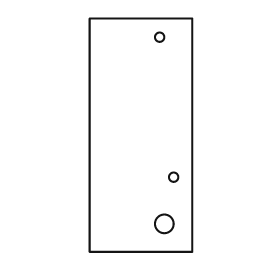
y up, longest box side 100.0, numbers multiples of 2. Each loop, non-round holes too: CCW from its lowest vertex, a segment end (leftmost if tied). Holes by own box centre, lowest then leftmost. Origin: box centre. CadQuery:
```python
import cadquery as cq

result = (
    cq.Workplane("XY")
    .moveTo(-22.0, -50.0)
    .lineTo(22.0, -50.0)
    .lineTo(22.0, 50.0)
    .lineTo(-22.0, 50.0)
    .close()
    .moveTo(10.0, -38.0)
    .circle(4.0)
    .moveTo(14.0, -18.0)
    .circle(2.0)
    .moveTo(8.0, 42.0)
    .circle(2.0)
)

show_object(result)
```